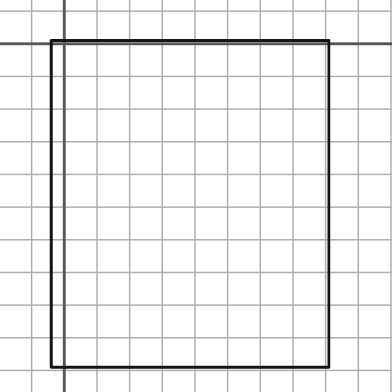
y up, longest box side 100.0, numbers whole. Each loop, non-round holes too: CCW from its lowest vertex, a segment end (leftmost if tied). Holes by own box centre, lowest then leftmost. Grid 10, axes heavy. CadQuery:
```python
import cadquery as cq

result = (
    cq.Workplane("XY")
    .moveTo(-4.0, -99.0)
    .lineTo(81.0, -99.0)
    .lineTo(81.0, 1.0)
    .lineTo(-4.0, 1.0)
    .close()
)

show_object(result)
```